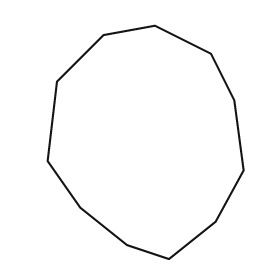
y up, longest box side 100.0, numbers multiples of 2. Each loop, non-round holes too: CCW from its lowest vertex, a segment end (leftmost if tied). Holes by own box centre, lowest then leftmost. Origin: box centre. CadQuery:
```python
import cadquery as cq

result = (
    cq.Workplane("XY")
    .moveTo(10.0, -50.0)
    .lineTo(30.0, -34.0)
    .lineTo(42.0, -12.0)
    .lineTo(38.0, 18.0)
    .lineTo(28.0, 38.0)
    .lineTo(4.0, 50.0)
    .lineTo(-18.0, 46.0)
    .lineTo(-38.0, 26.0)
    .lineTo(-42.0, -8.0)
    .lineTo(-28.0, -28.0)
    .lineTo(-8.0, -44.0)
    .close()
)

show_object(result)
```